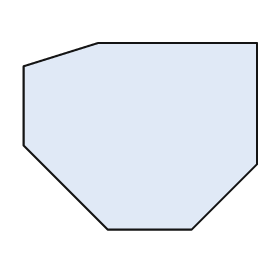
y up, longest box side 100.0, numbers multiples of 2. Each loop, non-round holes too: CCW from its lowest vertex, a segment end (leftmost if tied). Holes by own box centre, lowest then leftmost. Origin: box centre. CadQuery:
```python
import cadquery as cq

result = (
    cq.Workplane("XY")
    .moveTo(-14.0, -40.0)
    .lineTo(22.0, -40.0)
    .lineTo(50.0, -12.0)
    .lineTo(50.0, 40.0)
    .lineTo(-18.0, 40.0)
    .lineTo(-50.0, 30.0)
    .lineTo(-50.0, -4.0)
    .close()
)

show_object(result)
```